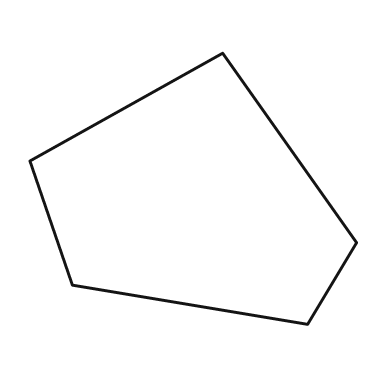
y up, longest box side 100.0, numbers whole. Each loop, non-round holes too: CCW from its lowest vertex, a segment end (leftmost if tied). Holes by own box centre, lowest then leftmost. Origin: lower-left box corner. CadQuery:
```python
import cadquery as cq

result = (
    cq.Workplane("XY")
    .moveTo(85.0, 0.0)
    .lineTo(100.0, 25.0)
    .lineTo(59.0, 83.0)
    .lineTo(0.0, 50.0)
    .lineTo(13.0, 12.0)
    .close()
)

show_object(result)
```